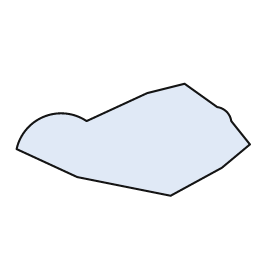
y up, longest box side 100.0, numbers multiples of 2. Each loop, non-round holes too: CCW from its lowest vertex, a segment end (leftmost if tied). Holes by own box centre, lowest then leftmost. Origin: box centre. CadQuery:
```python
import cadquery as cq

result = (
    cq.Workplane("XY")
    .moveTo(16.0, -24.0)
    .lineTo(38.0, -12.0)
    .lineTo(50.0, -2.0)
    .lineTo(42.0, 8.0)
    .threePointArc((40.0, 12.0), (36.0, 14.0))
    .lineTo(22.0, 24.0)
    .lineTo(6.0, 20.0)
    .lineTo(-20.0, 8.0)
    .threePointArc((-38.0, 10.0), (-50.0, -4.0))
    .lineTo(-24.0, -16.0)
    .close()
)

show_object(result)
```